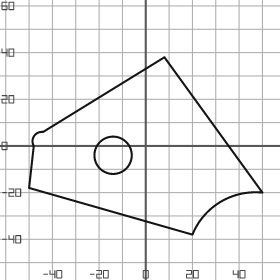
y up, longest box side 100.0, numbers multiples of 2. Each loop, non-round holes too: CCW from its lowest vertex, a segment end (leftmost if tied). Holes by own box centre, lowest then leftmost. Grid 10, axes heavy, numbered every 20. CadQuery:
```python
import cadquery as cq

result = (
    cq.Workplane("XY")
    .moveTo(20.0, -38.0)
    .threePointArc((32.0, -24.0), (50.0, -20.0))
    .lineTo(8.0, 38.0)
    .lineTo(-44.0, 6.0)
    .threePointArc((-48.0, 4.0), (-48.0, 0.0))
    .lineTo(-50.0, -18.0)
    .close()
    .moveTo(-14.0, -4.0)
    .circle(8.0)
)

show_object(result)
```